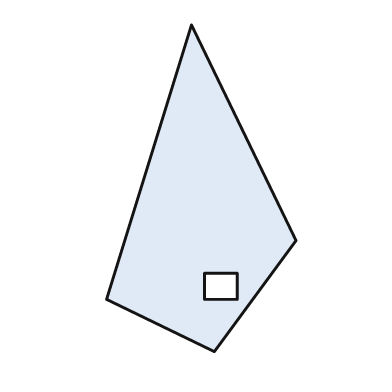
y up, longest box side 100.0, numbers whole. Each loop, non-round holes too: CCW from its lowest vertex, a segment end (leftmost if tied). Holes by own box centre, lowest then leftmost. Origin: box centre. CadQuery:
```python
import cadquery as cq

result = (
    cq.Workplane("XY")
    .moveTo(4.0, -50.0)
    .lineTo(29.0, -16.0)
    .lineTo(-3.0, 50.0)
    .lineTo(-29.0, -34.0)
    .close()
    .moveTo(1.0, -34.0)
    .lineTo(11.0, -34.0)
    .lineTo(11.0, -26.0)
    .lineTo(1.0, -26.0)
    .close()
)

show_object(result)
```